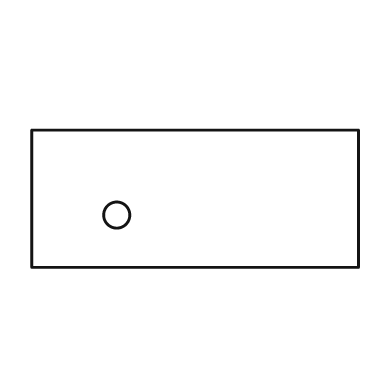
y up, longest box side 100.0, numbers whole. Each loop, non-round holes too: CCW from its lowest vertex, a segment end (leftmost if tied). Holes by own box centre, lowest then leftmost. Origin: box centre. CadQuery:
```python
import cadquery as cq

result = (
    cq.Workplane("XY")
    .moveTo(-50.0, -21.0)
    .lineTo(50.0, -21.0)
    .lineTo(50.0, 21.0)
    .lineTo(-50.0, 21.0)
    .close()
    .moveTo(-24.0, -5.0)
    .circle(4.0)
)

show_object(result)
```